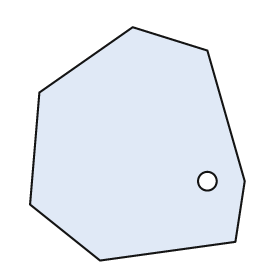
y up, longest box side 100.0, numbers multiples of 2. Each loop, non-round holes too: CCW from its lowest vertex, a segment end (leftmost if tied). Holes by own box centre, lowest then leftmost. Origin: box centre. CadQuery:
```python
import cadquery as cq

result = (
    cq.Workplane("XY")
    .moveTo(-16.0, -50.0)
    .lineTo(42.0, -42.0)
    .lineTo(46.0, -16.0)
    .lineTo(30.0, 40.0)
    .lineTo(-2.0, 50.0)
    .lineTo(-42.0, 22.0)
    .lineTo(-46.0, -26.0)
    .close()
    .moveTo(30.0, -16.0)
    .circle(4.0)
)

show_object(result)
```